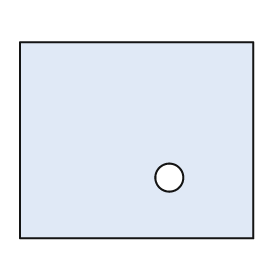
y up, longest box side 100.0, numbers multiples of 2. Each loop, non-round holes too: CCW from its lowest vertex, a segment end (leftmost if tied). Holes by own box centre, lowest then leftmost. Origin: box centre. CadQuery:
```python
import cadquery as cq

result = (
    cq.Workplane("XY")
    .moveTo(-50.0, -42.0)
    .lineTo(50.0, -42.0)
    .lineTo(50.0, 42.0)
    .lineTo(-50.0, 42.0)
    .close()
    .moveTo(14.0, -16.0)
    .circle(6.0)
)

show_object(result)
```